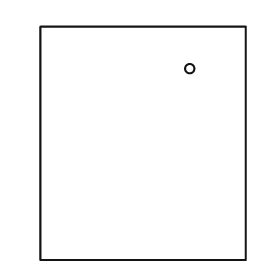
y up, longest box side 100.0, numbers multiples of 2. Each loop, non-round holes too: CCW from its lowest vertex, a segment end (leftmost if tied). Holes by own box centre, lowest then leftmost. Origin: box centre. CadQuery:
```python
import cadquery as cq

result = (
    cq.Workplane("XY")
    .moveTo(-44.0, -50.0)
    .lineTo(44.0, -50.0)
    .lineTo(44.0, 50.0)
    .lineTo(-44.0, 50.0)
    .close()
    .moveTo(20.0, 32.0)
    .circle(2.0)
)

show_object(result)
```